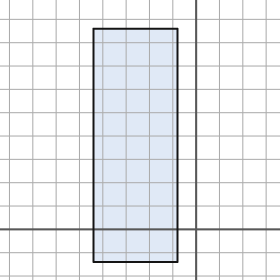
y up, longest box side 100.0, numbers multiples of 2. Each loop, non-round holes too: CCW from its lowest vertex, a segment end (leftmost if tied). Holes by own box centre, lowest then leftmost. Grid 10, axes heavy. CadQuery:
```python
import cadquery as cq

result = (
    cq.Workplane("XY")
    .moveTo(-44.0, -14.0)
    .lineTo(-8.0, -14.0)
    .lineTo(-8.0, 86.0)
    .lineTo(-44.0, 86.0)
    .close()
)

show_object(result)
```